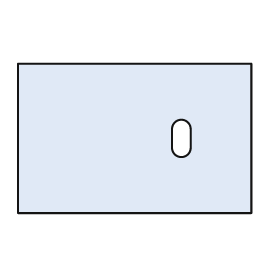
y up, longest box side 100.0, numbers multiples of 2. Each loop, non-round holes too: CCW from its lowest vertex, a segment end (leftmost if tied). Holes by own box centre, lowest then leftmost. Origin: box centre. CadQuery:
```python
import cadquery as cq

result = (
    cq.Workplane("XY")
    .moveTo(-50.0, -32.0)
    .lineTo(50.0, -32.0)
    .lineTo(50.0, 32.0)
    .lineTo(-50.0, 32.0)
    .close()
    .moveTo(16.0, -4.0)
    .threePointArc((20.0, -8.0), (24.0, -4.0))
    .lineTo(24.0, 4.0)
    .threePointArc((20.0, 8.0), (16.0, 4.0))
    .close()
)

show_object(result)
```